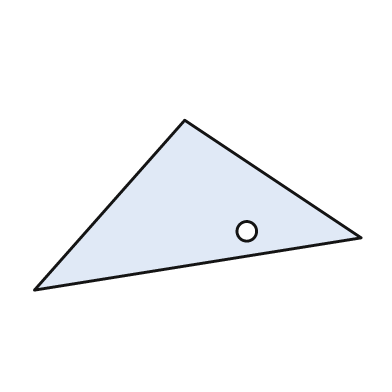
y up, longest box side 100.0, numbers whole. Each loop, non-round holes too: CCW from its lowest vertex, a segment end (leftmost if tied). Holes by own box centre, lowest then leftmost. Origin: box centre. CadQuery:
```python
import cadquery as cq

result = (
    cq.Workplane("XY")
    .moveTo(-50.0, -26.0)
    .lineTo(50.0, -10.0)
    .lineTo(-4.0, 26.0)
    .close()
    .moveTo(15.0, -8.0)
    .circle(3.0)
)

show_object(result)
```